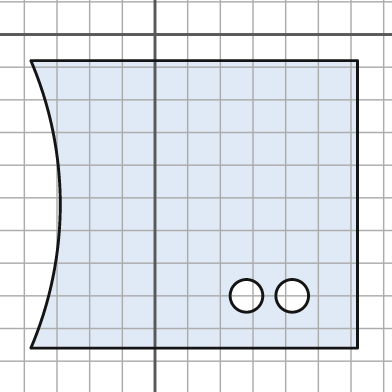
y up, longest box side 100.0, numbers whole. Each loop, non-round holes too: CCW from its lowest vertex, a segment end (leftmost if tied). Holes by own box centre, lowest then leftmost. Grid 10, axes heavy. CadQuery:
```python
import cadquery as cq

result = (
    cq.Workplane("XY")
    .moveTo(-38.0, -96.0)
    .lineTo(62.0, -96.0)
    .lineTo(62.0, -8.0)
    .lineTo(-38.0, -8.0)
    .threePointArc((-29.0, -52.0), (-38.0, -96.0))
    .close()
    .moveTo(28.0, -80.0)
    .circle(5.0)
    .moveTo(42.0, -80.0)
    .circle(5.0)
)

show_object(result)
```